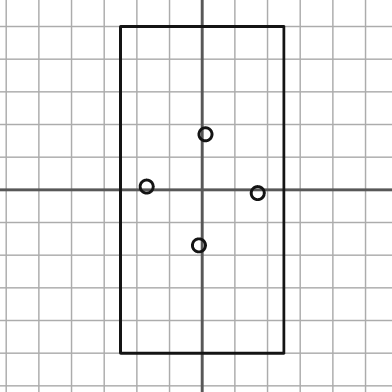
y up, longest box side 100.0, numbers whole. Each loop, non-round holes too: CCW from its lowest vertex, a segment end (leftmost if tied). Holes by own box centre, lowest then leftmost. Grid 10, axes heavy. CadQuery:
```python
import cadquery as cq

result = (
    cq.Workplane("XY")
    .moveTo(-25.0, -50.0)
    .lineTo(25.0, -50.0)
    .lineTo(25.0, 50.0)
    .lineTo(-25.0, 50.0)
    .close()
    .moveTo(-1.0, -17.0)
    .circle(2.0)
    .moveTo(17.0, -1.0)
    .circle(2.0)
    .moveTo(-17.0, 1.0)
    .circle(2.0)
    .moveTo(1.0, 17.0)
    .circle(2.0)
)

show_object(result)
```